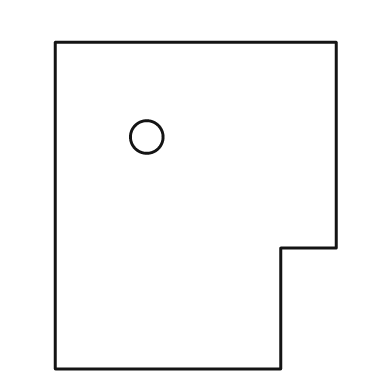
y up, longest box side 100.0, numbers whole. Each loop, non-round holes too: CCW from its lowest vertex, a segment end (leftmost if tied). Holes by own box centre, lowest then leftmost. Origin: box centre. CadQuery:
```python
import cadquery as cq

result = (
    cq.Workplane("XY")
    .moveTo(-43.0, -50.0)
    .lineTo(26.0, -50.0)
    .lineTo(26.0, -13.0)
    .lineTo(43.0, -13.0)
    .lineTo(43.0, 50.0)
    .lineTo(-43.0, 50.0)
    .close()
    .moveTo(-15.0, 21.0)
    .circle(5.0)
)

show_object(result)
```